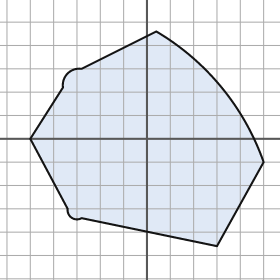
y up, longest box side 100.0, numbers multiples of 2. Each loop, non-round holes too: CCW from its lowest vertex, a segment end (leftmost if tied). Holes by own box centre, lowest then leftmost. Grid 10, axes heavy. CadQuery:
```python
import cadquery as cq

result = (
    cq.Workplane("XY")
    .moveTo(30.0, -46.0)
    .lineTo(50.0, -10.0)
    .threePointArc((32.0, 22.0), (4.0, 46.0))
    .lineTo(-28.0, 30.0)
    .threePointArc((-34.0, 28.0), (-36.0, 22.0))
    .lineTo(-50.0, 0.0)
    .lineTo(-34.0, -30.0)
    .threePointArc((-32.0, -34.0), (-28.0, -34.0))
    .close()
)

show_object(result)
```